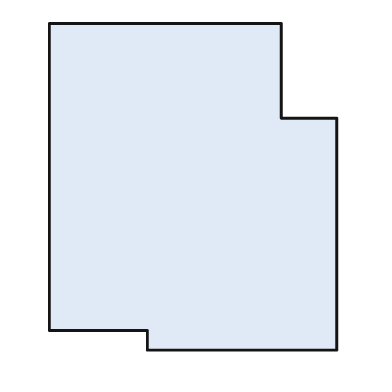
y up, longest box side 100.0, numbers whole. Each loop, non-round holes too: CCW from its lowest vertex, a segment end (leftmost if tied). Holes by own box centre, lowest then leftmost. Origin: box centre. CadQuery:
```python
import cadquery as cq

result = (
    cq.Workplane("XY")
    .moveTo(-14.0, -50.0)
    .lineTo(44.0, -50.0)
    .lineTo(44.0, 21.0)
    .lineTo(27.0, 21.0)
    .lineTo(27.0, 50.0)
    .lineTo(-44.0, 50.0)
    .lineTo(-44.0, -44.0)
    .lineTo(-14.0, -44.0)
    .close()
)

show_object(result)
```